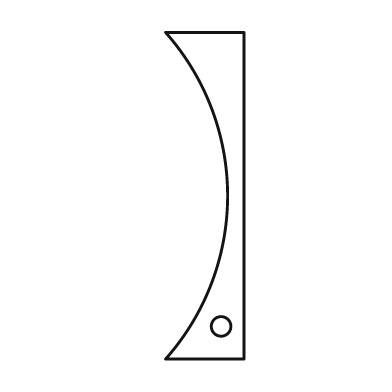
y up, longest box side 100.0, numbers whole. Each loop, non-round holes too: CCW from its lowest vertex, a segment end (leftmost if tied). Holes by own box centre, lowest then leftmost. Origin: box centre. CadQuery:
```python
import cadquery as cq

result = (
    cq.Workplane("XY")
    .moveTo(-12.0, -50.0)
    .lineTo(12.0, -50.0)
    .lineTo(12.0, 50.0)
    .lineTo(-12.0, 50.0)
    .threePointArc((7.0, 0.0), (-12.0, -50.0))
    .close()
    .moveTo(5.0, -40.0)
    .circle(3.0)
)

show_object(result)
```